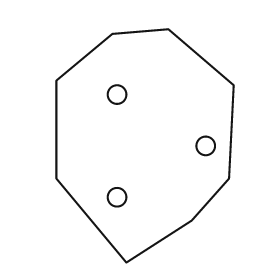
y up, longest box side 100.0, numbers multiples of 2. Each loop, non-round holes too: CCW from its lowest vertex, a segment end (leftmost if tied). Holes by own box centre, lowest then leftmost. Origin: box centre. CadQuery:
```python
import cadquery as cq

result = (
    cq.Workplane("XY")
    .moveTo(-8.0, -50.0)
    .lineTo(20.0, -32.0)
    .lineTo(36.0, -14.0)
    .lineTo(38.0, 26.0)
    .lineTo(10.0, 50.0)
    .lineTo(-14.0, 48.0)
    .lineTo(-38.0, 28.0)
    .lineTo(-38.0, -14.0)
    .close()
    .moveTo(-12.0, -22.0)
    .circle(4.0)
    .moveTo(26.0, 0.0)
    .circle(4.0)
    .moveTo(-12.0, 22.0)
    .circle(4.0)
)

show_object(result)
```